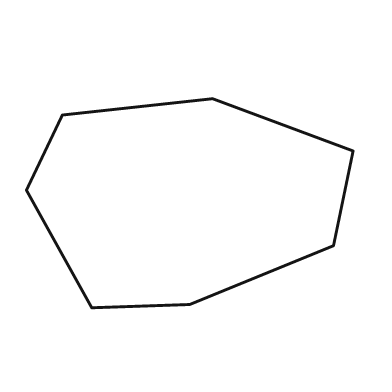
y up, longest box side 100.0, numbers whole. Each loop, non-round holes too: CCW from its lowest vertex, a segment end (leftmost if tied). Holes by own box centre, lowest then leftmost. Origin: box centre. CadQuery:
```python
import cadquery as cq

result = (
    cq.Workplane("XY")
    .moveTo(-30.0, -32.0)
    .lineTo(0.0, -31.0)
    .lineTo(44.0, -13.0)
    .lineTo(50.0, 16.0)
    .lineTo(7.0, 32.0)
    .lineTo(-39.0, 27.0)
    .lineTo(-50.0, 4.0)
    .close()
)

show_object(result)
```